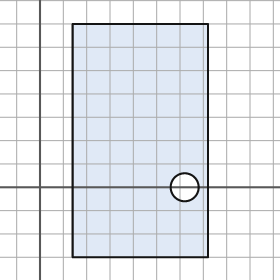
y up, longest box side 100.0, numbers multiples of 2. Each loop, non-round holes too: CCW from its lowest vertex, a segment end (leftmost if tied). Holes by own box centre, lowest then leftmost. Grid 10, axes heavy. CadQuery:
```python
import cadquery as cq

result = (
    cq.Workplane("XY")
    .moveTo(14.0, -30.0)
    .lineTo(72.0, -30.0)
    .lineTo(72.0, 70.0)
    .lineTo(14.0, 70.0)
    .close()
    .moveTo(62.0, 0.0)
    .circle(6.0)
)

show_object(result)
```